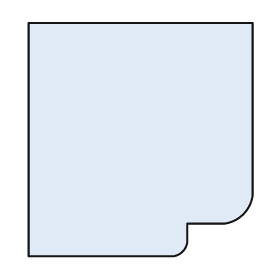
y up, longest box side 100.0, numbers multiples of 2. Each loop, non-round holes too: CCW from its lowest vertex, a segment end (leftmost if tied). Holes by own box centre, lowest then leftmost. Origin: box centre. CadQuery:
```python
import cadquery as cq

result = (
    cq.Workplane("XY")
    .moveTo(-48.0, -50.0)
    .lineTo(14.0, -50.0)
    .threePointArc((18.0, -48.0), (20.0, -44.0))
    .lineTo(20.0, -36.0)
    .lineTo(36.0, -36.0)
    .threePointArc((44.0, -32.0), (48.0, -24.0))
    .lineTo(48.0, 50.0)
    .lineTo(-48.0, 50.0)
    .close()
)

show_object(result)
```